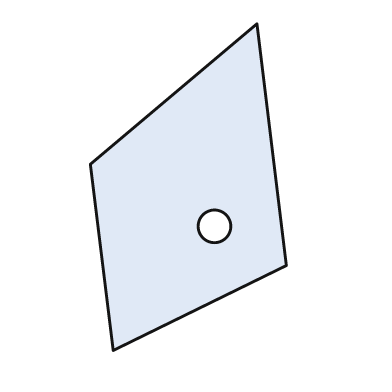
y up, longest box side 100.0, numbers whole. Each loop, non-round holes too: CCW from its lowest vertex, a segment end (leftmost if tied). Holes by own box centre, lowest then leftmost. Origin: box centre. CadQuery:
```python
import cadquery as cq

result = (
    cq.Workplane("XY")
    .moveTo(-23.0, -50.0)
    .lineTo(30.0, -24.0)
    .lineTo(21.0, 50.0)
    .lineTo(-30.0, 7.0)
    .close()
    .moveTo(8.0, -12.0)
    .circle(5.0)
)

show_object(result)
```